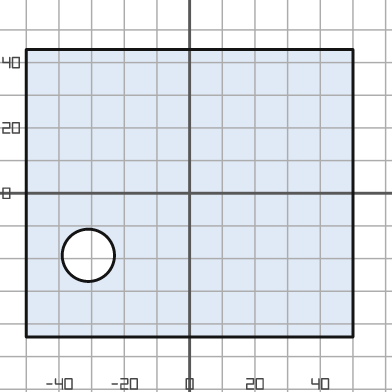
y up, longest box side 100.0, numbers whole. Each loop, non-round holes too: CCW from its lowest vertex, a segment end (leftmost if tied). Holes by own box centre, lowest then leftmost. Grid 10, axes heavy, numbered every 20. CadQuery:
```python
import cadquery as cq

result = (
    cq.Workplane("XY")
    .moveTo(-50.0, -44.0)
    .lineTo(50.0, -44.0)
    .lineTo(50.0, 44.0)
    .lineTo(-50.0, 44.0)
    .close()
    .moveTo(-31.0, -19.0)
    .circle(8.0)
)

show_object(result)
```